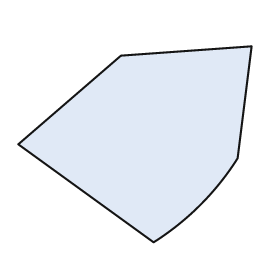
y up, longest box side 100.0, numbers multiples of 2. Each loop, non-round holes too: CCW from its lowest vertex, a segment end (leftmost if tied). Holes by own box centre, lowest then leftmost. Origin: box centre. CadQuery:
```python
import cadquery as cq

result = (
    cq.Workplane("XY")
    .moveTo(8.0, -42.0)
    .threePointArc((28.0, -26.0), (44.0, -6.0))
    .lineTo(50.0, 42.0)
    .lineTo(-6.0, 38.0)
    .lineTo(-50.0, 0.0)
    .close()
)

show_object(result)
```